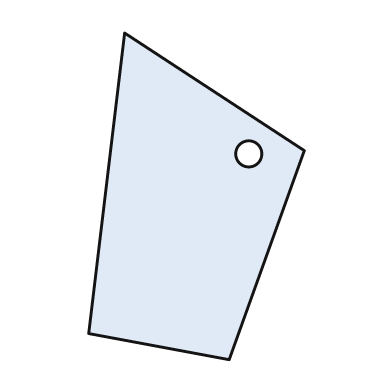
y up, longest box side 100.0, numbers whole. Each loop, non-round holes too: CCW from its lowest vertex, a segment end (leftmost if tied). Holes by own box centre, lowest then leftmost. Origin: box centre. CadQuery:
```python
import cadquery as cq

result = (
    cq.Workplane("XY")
    .moveTo(10.0, -50.0)
    .lineTo(33.0, 14.0)
    .lineTo(-22.0, 50.0)
    .lineTo(-33.0, -42.0)
    .close()
    .moveTo(16.0, 13.0)
    .circle(4.0)
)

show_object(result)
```